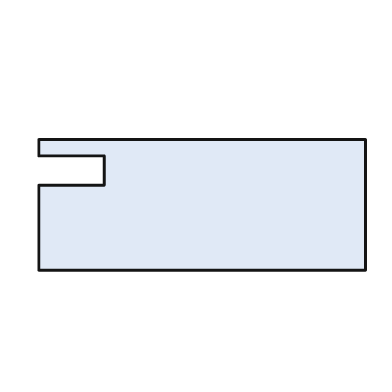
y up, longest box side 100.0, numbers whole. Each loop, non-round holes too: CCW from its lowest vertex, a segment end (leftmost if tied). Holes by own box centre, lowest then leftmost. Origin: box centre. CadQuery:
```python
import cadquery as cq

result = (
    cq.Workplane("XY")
    .moveTo(-50.0, -20.0)
    .lineTo(50.0, -20.0)
    .lineTo(50.0, 20.0)
    .lineTo(-50.0, 20.0)
    .lineTo(-50.0, 15.0)
    .lineTo(-30.0, 15.0)
    .lineTo(-30.0, 6.0)
    .lineTo(-50.0, 6.0)
    .close()
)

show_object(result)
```